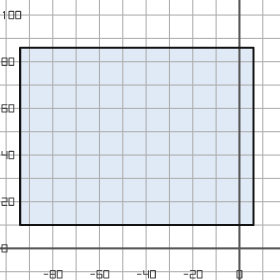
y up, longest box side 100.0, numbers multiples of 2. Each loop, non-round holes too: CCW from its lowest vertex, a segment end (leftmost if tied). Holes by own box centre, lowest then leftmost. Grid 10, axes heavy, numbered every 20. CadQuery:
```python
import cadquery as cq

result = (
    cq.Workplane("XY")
    .moveTo(-94.0, 10.0)
    .lineTo(6.0, 10.0)
    .lineTo(6.0, 86.0)
    .lineTo(-94.0, 86.0)
    .close()
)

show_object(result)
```